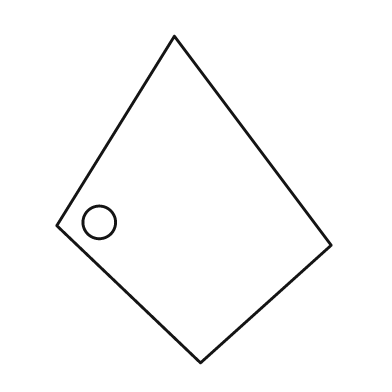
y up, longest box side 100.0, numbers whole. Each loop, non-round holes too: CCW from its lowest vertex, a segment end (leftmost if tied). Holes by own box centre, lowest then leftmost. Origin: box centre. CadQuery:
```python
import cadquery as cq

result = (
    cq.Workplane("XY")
    .moveTo(2.0, -50.0)
    .lineTo(42.0, -14.0)
    .lineTo(-6.0, 50.0)
    .lineTo(-42.0, -8.0)
    .close()
    .moveTo(-29.0, -7.0)
    .circle(5.0)
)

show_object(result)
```